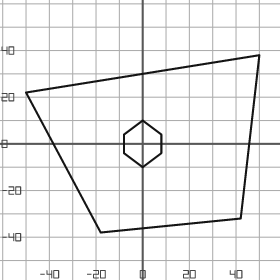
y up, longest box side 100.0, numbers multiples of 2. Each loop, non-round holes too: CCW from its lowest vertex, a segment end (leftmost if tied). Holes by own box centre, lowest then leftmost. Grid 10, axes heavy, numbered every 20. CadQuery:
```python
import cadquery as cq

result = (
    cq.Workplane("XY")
    .moveTo(-18.0, -38.0)
    .lineTo(42.0, -32.0)
    .lineTo(50.0, 38.0)
    .lineTo(-50.0, 22.0)
    .close()
    .moveTo(0.0, -10.0)
    .lineTo(8.0, -4.0)
    .lineTo(8.0, 4.0)
    .lineTo(0.0, 10.0)
    .lineTo(-8.0, 4.0)
    .lineTo(-8.0, -4.0)
    .close()
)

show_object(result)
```